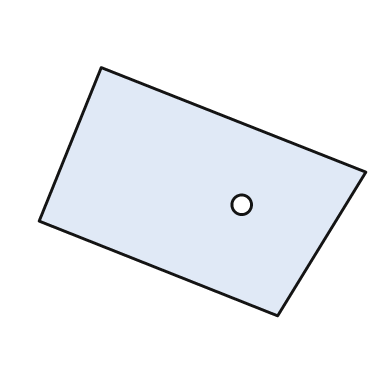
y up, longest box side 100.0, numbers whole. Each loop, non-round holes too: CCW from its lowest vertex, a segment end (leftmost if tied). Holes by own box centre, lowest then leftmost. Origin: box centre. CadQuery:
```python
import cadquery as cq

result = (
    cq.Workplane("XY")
    .moveTo(23.0, -38.0)
    .lineTo(50.0, 6.0)
    .lineTo(-31.0, 38.0)
    .lineTo(-50.0, -9.0)
    .close()
    .moveTo(12.0, -4.0)
    .circle(3.0)
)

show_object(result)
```